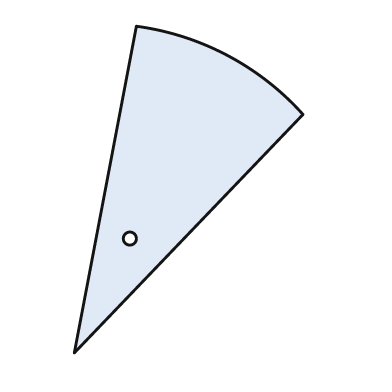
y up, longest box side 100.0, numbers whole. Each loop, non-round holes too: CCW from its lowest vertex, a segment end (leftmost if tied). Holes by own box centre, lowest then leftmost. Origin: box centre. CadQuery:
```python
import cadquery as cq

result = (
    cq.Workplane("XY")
    .moveTo(-35.0, -50.0)
    .lineTo(35.0, 23.0)
    .threePointArc((12.0, 41.0), (-16.0, 50.0))
    .close()
    .moveTo(-18.0, -15.0)
    .circle(2.0)
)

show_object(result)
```